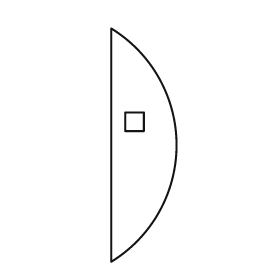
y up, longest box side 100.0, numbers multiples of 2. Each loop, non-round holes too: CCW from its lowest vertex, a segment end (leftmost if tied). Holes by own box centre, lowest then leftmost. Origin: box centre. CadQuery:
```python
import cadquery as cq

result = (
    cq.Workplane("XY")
    .moveTo(-14.0, -50.0)
    .threePointArc((14.0, 0.0), (-14.0, 50.0))
    .close()
    .moveTo(-8.0, 6.0)
    .lineTo(0.0, 6.0)
    .lineTo(0.0, 14.0)
    .lineTo(-8.0, 14.0)
    .close()
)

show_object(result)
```